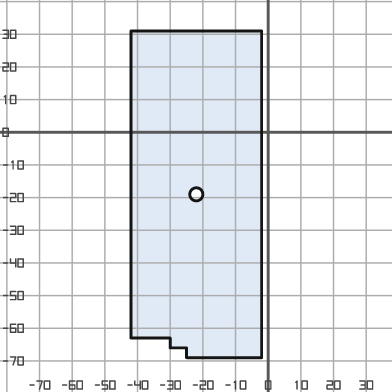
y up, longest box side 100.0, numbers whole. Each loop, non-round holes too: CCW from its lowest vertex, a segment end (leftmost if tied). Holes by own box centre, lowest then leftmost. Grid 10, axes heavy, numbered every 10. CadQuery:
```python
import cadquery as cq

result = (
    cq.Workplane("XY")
    .moveTo(-25.0, -69.0)
    .lineTo(-2.0, -69.0)
    .lineTo(-2.0, 31.0)
    .lineTo(-42.0, 31.0)
    .lineTo(-42.0, -63.0)
    .lineTo(-30.0, -63.0)
    .lineTo(-30.0, -66.0)
    .lineTo(-25.0, -66.0)
    .close()
    .moveTo(-22.0, -19.0)
    .circle(2.0)
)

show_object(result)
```